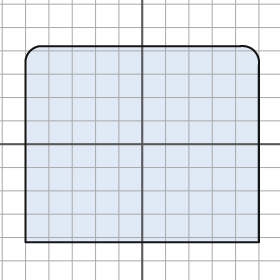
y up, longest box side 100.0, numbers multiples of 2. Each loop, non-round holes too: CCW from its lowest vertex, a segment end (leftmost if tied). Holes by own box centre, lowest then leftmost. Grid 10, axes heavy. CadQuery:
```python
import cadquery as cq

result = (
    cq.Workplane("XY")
    .moveTo(-50.0, -42.0)
    .lineTo(50.0, -42.0)
    .lineTo(50.0, 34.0)
    .threePointArc((48.0, 40.0), (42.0, 42.0))
    .lineTo(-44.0, 42.0)
    .threePointArc((-48.0, 40.0), (-50.0, 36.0))
    .close()
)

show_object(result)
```